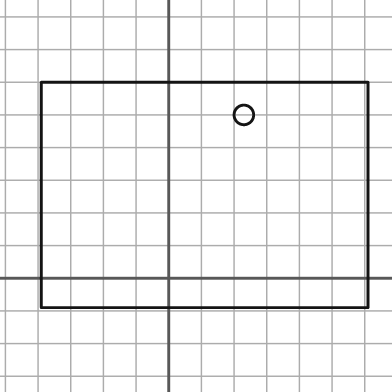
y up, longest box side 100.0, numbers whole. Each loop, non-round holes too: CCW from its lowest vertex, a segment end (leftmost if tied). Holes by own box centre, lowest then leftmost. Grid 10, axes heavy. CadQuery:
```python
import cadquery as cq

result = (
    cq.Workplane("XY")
    .moveTo(-39.0, -9.0)
    .lineTo(61.0, -9.0)
    .lineTo(61.0, 60.0)
    .lineTo(-39.0, 60.0)
    .close()
    .moveTo(23.0, 50.0)
    .circle(3.0)
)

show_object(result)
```